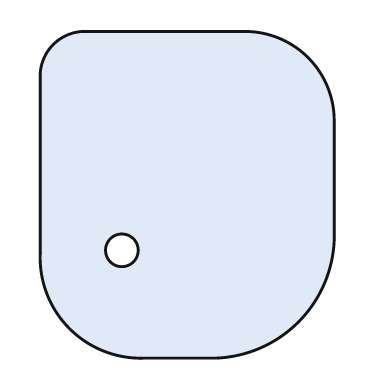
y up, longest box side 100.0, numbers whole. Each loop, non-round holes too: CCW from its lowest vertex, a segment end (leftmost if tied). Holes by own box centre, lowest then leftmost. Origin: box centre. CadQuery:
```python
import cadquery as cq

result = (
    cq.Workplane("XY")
    .moveTo(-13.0, -50.0)
    .lineTo(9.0, -50.0)
    .threePointArc((34.0, -39.0), (45.0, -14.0))
    .lineTo(45.0, 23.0)
    .threePointArc((37.0, 42.0), (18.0, 50.0))
    .lineTo(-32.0, 50.0)
    .threePointArc((-41.0, 46.0), (-45.0, 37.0))
    .lineTo(-45.0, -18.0)
    .threePointArc((-36.0, -41.0), (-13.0, -50.0))
    .close()
    .moveTo(-20.0, -17.0)
    .circle(5.0)
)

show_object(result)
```